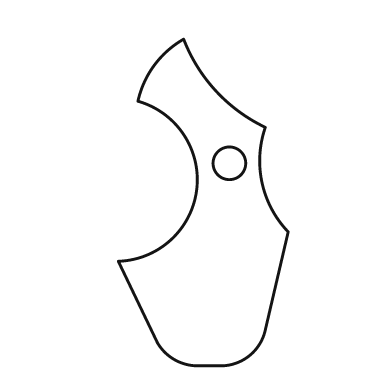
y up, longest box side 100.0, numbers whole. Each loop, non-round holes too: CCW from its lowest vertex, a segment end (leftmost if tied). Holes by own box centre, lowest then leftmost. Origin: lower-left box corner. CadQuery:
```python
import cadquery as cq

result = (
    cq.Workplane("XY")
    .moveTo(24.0, 0.0)
    .lineTo(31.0, 0.0)
    .threePointArc((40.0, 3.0), (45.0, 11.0))
    .lineTo(52.0, 41.0)
    .threePointArc((44.0, 56.0), (45.0, 73.0))
    .threePointArc((30.0, 84.0), (20.0, 100.0))
    .threePointArc((11.0, 92.0), (6.0, 81.0))
    .threePointArc((24.0, 54.0), (0.0, 32.0))
    .lineTo(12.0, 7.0)
    .threePointArc((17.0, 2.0), (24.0, 0.0))
    .close()
    .moveTo(34.0, 62.0)
    .circle(5.0)
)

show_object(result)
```